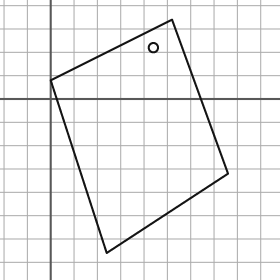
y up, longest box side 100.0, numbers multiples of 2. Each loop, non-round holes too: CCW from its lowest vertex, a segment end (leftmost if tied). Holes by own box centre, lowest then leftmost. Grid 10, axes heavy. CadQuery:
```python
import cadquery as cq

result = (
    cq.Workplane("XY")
    .moveTo(24.0, -66.0)
    .lineTo(76.0, -32.0)
    .lineTo(52.0, 34.0)
    .lineTo(0.0, 8.0)
    .close()
    .moveTo(44.0, 22.0)
    .circle(2.0)
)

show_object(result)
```